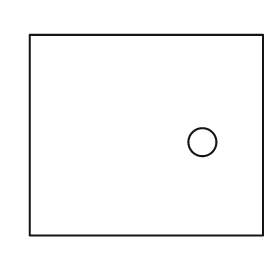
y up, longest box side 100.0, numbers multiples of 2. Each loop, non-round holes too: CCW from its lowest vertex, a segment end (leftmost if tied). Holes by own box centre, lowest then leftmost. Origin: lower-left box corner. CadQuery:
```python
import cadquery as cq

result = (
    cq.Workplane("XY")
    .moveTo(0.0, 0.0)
    .lineTo(100.0, 0.0)
    .lineTo(100.0, 86.0)
    .lineTo(0.0, 86.0)
    .close()
    .moveTo(74.0, 40.0)
    .circle(6.0)
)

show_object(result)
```